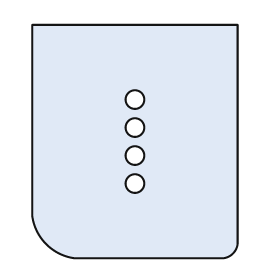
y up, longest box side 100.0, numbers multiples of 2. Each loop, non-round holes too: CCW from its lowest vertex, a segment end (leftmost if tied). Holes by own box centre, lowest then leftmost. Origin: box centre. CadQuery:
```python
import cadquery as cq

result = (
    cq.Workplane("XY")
    .moveTo(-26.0, -50.0)
    .lineTo(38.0, -50.0)
    .threePointArc((42.0, -48.0), (44.0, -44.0))
    .lineTo(44.0, 50.0)
    .lineTo(-44.0, 50.0)
    .lineTo(-44.0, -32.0)
    .threePointArc((-38.0, -44.0), (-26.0, -50.0))
    .close()
    .moveTo(0.0, -18.0)
    .circle(4.0)
    .moveTo(0.0, -6.0)
    .circle(4.0)
    .moveTo(0.0, 6.0)
    .circle(4.0)
    .moveTo(0.0, 18.0)
    .circle(4.0)
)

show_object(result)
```